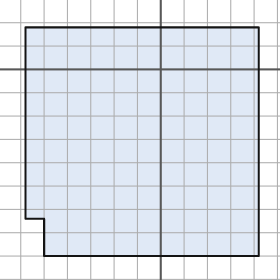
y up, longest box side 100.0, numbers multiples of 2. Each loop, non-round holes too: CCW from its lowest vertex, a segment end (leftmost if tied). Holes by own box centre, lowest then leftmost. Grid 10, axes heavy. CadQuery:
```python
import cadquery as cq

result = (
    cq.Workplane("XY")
    .moveTo(-50.0, -80.0)
    .lineTo(42.0, -80.0)
    .lineTo(42.0, 18.0)
    .lineTo(-58.0, 18.0)
    .lineTo(-58.0, -64.0)
    .lineTo(-50.0, -64.0)
    .close()
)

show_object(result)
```